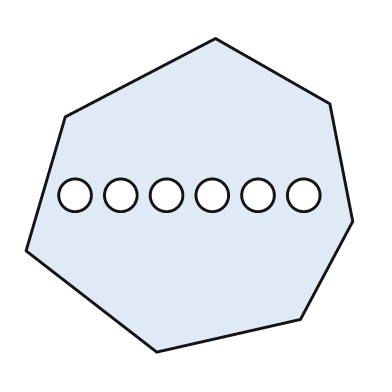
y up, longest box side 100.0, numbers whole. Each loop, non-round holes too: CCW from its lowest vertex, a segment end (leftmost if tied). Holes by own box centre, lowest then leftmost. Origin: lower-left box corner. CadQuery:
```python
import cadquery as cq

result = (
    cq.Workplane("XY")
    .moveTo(40.0, 0.0)
    .lineTo(84.0, 10.0)
    .lineTo(100.0, 40.0)
    .lineTo(93.0, 76.0)
    .lineTo(58.0, 96.0)
    .lineTo(12.0, 72.0)
    .lineTo(0.0, 31.0)
    .close()
    .moveTo(15.0, 48.0)
    .circle(5.0)
    .moveTo(29.0, 48.0)
    .circle(5.0)
    .moveTo(43.0, 48.0)
    .circle(5.0)
    .moveTo(57.0, 48.0)
    .circle(5.0)
    .moveTo(71.0, 48.0)
    .circle(5.0)
    .moveTo(85.0, 48.0)
    .circle(5.0)
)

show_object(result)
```